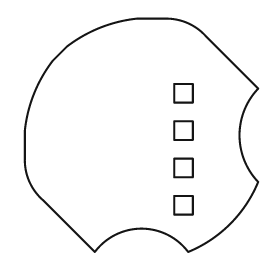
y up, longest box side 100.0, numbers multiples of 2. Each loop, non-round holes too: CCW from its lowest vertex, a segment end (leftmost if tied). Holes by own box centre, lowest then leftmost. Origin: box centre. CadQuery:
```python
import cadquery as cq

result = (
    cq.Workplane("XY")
    .moveTo(-20.0, -50.0)
    .threePointArc((0.0, -40.0), (20.0, -50.0))
    .threePointArc((38.0, -38.0), (50.0, -20.0))
    .threePointArc((42.0, 0.0), (50.0, 20.0))
    .lineTo(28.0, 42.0)
    .threePointArc((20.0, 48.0), (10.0, 50.0))
    .lineTo(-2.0, 50.0)
    .threePointArc((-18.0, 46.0), (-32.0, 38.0))
    .lineTo(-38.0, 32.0)
    .threePointArc((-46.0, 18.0), (-50.0, 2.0))
    .lineTo(-50.0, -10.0)
    .threePointArc((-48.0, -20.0), (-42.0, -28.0))
    .close()
    .moveTo(14.0, -34.0)
    .lineTo(22.0, -34.0)
    .lineTo(22.0, -26.0)
    .lineTo(14.0, -26.0)
    .close()
    .moveTo(14.0, -18.0)
    .lineTo(22.0, -18.0)
    .lineTo(22.0, -10.0)
    .lineTo(14.0, -10.0)
    .close()
    .moveTo(14.0, -2.0)
    .lineTo(22.0, -2.0)
    .lineTo(22.0, 6.0)
    .lineTo(14.0, 6.0)
    .close()
    .moveTo(14.0, 14.0)
    .lineTo(22.0, 14.0)
    .lineTo(22.0, 22.0)
    .lineTo(14.0, 22.0)
    .close()
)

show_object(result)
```